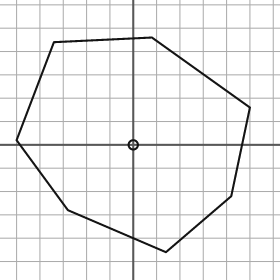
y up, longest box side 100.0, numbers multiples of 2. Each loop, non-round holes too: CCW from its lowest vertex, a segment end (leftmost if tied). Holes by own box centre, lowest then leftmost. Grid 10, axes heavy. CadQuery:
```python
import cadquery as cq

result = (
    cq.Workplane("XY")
    .moveTo(14.0, -46.0)
    .lineTo(42.0, -22.0)
    .lineTo(50.0, 16.0)
    .lineTo(8.0, 46.0)
    .lineTo(-34.0, 44.0)
    .lineTo(-50.0, 2.0)
    .lineTo(-28.0, -28.0)
    .close()
    .moveTo(0.0, 0.0)
    .circle(2.0)
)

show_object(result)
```